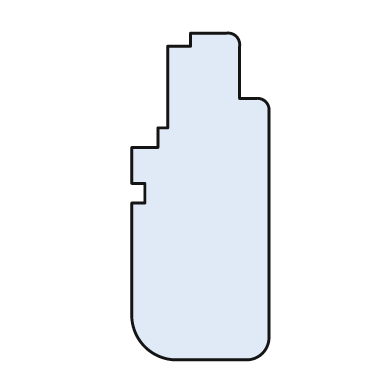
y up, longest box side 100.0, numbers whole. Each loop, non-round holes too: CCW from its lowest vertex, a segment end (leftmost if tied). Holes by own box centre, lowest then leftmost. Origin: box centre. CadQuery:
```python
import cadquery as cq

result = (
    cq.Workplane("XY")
    .moveTo(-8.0, -50.0)
    .lineTo(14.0, -50.0)
    .threePointArc((19.0, -48.0), (21.0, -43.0))
    .lineTo(21.0, 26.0)
    .threePointArc((20.0, 29.0), (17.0, 30.0))
    .lineTo(12.0, 30.0)
    .lineTo(12.0, 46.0)
    .threePointArc((11.0, 49.0), (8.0, 50.0))
    .lineTo(-3.0, 50.0)
    .lineTo(-3.0, 46.0)
    .lineTo(-10.0, 46.0)
    .lineTo(-10.0, 21.0)
    .lineTo(-13.0, 21.0)
    .lineTo(-13.0, 15.0)
    .lineTo(-21.0, 15.0)
    .lineTo(-21.0, 4.0)
    .lineTo(-17.0, 4.0)
    .lineTo(-17.0, -2.0)
    .lineTo(-21.0, -2.0)
    .lineTo(-21.0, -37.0)
    .threePointArc((-17.0, -46.0), (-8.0, -50.0))
    .close()
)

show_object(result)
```